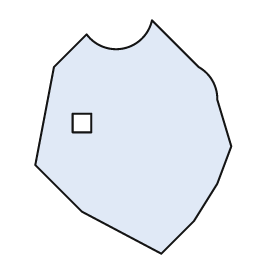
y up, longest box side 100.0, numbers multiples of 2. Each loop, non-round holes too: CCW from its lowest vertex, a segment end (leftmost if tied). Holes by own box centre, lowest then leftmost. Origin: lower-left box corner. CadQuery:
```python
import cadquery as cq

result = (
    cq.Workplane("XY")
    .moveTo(54.0, 0.0)
    .lineTo(68.0, 14.0)
    .lineTo(78.0, 30.0)
    .lineTo(84.0, 46.0)
    .lineTo(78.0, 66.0)
    .threePointArc((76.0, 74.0), (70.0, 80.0))
    .lineTo(50.0, 100.0)
    .threePointArc((38.0, 88.0), (22.0, 94.0))
    .lineTo(8.0, 80.0)
    .lineTo(0.0, 38.0)
    .lineTo(20.0, 18.0)
    .close()
    .moveTo(16.0, 52.0)
    .lineTo(24.0, 52.0)
    .lineTo(24.0, 60.0)
    .lineTo(16.0, 60.0)
    .close()
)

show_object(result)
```